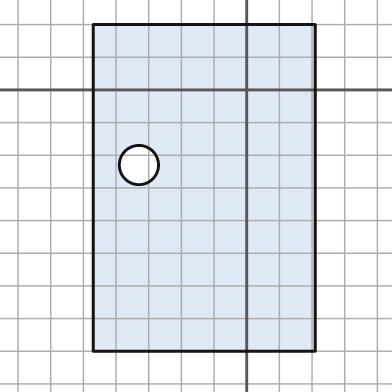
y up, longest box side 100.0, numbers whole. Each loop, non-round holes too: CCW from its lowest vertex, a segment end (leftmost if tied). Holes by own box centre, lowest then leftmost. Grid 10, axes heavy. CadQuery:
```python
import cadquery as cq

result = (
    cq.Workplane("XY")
    .moveTo(-47.0, -80.0)
    .lineTo(21.0, -80.0)
    .lineTo(21.0, 20.0)
    .lineTo(-47.0, 20.0)
    .close()
    .moveTo(-33.0, -23.0)
    .circle(6.0)
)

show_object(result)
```